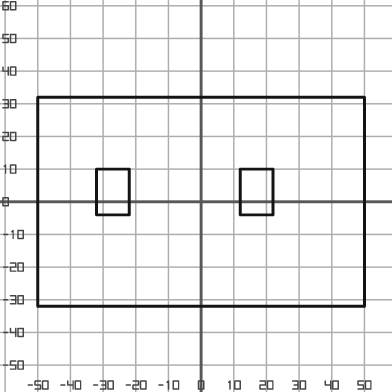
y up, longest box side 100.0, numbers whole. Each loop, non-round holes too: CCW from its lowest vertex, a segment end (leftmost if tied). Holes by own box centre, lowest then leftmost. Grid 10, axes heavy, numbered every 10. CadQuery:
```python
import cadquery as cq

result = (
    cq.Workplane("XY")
    .moveTo(-50.0, -32.0)
    .lineTo(50.0, -32.0)
    .lineTo(50.0, 32.0)
    .lineTo(-50.0, 32.0)
    .close()
    .moveTo(-32.0, -4.0)
    .lineTo(-22.0, -4.0)
    .lineTo(-22.0, 10.0)
    .lineTo(-32.0, 10.0)
    .close()
    .moveTo(12.0, -4.0)
    .lineTo(22.0, -4.0)
    .lineTo(22.0, 10.0)
    .lineTo(12.0, 10.0)
    .close()
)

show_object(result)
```